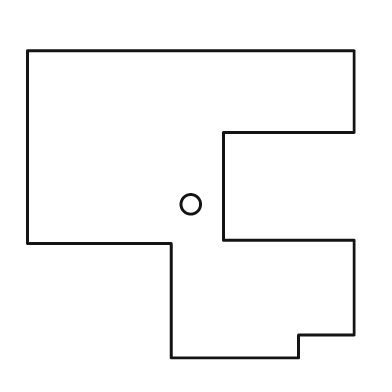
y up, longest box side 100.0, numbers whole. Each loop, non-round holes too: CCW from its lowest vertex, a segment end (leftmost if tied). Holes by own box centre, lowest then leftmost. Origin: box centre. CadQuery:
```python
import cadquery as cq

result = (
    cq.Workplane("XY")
    .moveTo(-6.0, -47.0)
    .lineTo(33.0, -47.0)
    .lineTo(33.0, -40.0)
    .lineTo(50.0, -40.0)
    .lineTo(50.0, -11.0)
    .lineTo(10.0, -11.0)
    .lineTo(10.0, 22.0)
    .lineTo(50.0, 22.0)
    .lineTo(50.0, 47.0)
    .lineTo(-50.0, 47.0)
    .lineTo(-50.0, -12.0)
    .lineTo(-6.0, -12.0)
    .close()
    .moveTo(0.0, 0.0)
    .circle(3.0)
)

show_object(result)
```